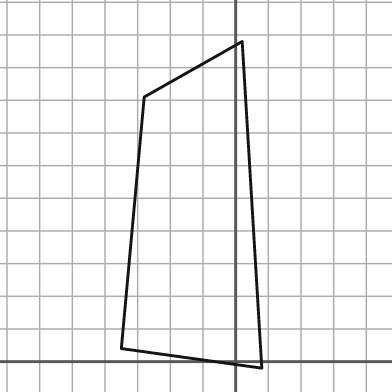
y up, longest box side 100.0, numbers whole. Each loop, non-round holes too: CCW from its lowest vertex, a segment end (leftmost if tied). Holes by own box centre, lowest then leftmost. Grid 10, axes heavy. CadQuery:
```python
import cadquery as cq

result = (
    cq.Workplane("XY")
    .moveTo(8.0, -2.0)
    .lineTo(2.0, 98.0)
    .lineTo(-28.0, 81.0)
    .lineTo(-35.0, 4.0)
    .close()
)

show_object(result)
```